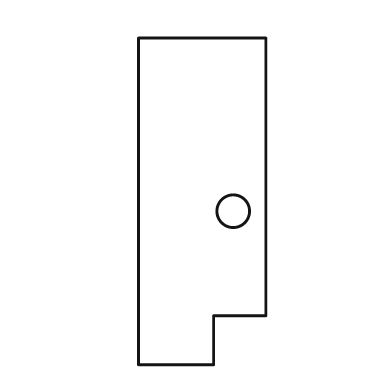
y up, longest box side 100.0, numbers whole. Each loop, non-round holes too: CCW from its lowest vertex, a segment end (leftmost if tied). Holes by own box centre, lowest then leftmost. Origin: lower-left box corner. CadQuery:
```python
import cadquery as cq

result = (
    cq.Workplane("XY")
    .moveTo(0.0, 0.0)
    .lineTo(23.0, 0.0)
    .lineTo(23.0, 15.0)
    .lineTo(39.0, 15.0)
    .lineTo(39.0, 100.0)
    .lineTo(0.0, 100.0)
    .close()
    .moveTo(29.0, 47.0)
    .circle(5.0)
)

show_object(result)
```